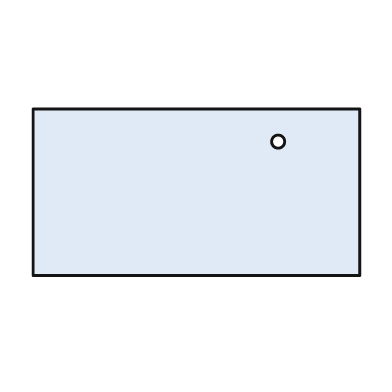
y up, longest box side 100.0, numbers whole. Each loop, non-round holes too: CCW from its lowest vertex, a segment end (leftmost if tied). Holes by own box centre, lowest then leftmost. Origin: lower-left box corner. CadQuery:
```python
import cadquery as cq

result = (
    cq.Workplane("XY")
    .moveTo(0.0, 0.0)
    .lineTo(100.0, 0.0)
    .lineTo(100.0, 51.0)
    .lineTo(0.0, 51.0)
    .close()
    .moveTo(75.0, 41.0)
    .circle(2.0)
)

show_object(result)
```